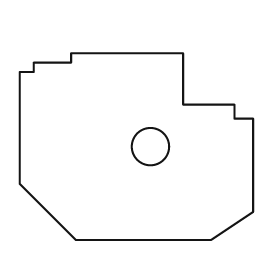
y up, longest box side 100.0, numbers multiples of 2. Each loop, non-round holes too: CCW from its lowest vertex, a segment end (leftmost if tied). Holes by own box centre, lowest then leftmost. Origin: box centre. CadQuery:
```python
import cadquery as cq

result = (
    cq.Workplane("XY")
    .moveTo(-26.0, -40.0)
    .lineTo(32.0, -40.0)
    .lineTo(50.0, -28.0)
    .lineTo(50.0, 12.0)
    .lineTo(42.0, 12.0)
    .lineTo(42.0, 18.0)
    .lineTo(20.0, 18.0)
    .lineTo(20.0, 40.0)
    .lineTo(-28.0, 40.0)
    .lineTo(-28.0, 36.0)
    .lineTo(-44.0, 36.0)
    .lineTo(-44.0, 32.0)
    .lineTo(-50.0, 32.0)
    .lineTo(-50.0, -16.0)
    .close()
    .moveTo(6.0, 0.0)
    .circle(8.0)
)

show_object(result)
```